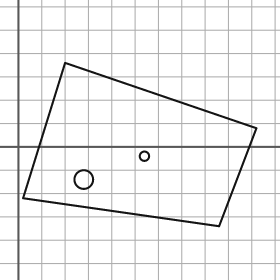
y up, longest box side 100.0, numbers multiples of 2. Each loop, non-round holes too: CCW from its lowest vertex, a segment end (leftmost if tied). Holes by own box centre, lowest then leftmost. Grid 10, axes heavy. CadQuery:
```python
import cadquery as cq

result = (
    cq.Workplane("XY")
    .moveTo(86.0, -34.0)
    .lineTo(102.0, 8.0)
    .lineTo(20.0, 36.0)
    .lineTo(2.0, -22.0)
    .close()
    .moveTo(28.0, -14.0)
    .circle(4.0)
    .moveTo(54.0, -4.0)
    .circle(2.0)
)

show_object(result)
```